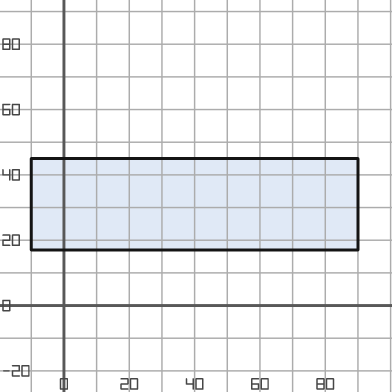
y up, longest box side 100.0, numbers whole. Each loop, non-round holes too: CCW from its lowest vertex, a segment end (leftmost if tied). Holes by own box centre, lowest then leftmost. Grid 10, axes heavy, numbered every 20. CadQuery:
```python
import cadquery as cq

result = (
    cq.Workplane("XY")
    .moveTo(-10.0, 17.0)
    .lineTo(90.0, 17.0)
    .lineTo(90.0, 45.0)
    .lineTo(-10.0, 45.0)
    .close()
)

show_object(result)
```